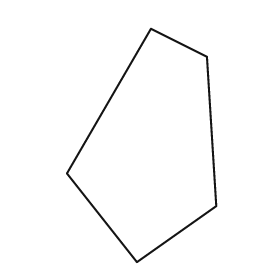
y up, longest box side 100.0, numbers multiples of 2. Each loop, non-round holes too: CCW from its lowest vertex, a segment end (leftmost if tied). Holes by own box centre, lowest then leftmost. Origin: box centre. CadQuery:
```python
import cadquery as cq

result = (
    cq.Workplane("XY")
    .moveTo(-2.0, -50.0)
    .lineTo(32.0, -26.0)
    .lineTo(28.0, 38.0)
    .lineTo(4.0, 50.0)
    .lineTo(-32.0, -12.0)
    .close()
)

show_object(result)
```